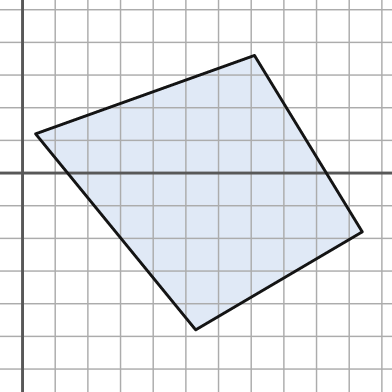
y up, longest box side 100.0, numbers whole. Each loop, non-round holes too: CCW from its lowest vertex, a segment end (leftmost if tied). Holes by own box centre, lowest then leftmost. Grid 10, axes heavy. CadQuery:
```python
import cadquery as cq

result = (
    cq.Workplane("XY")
    .moveTo(53.0, -48.0)
    .lineTo(104.0, -18.0)
    .lineTo(71.0, 36.0)
    .lineTo(4.0, 12.0)
    .close()
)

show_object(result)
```